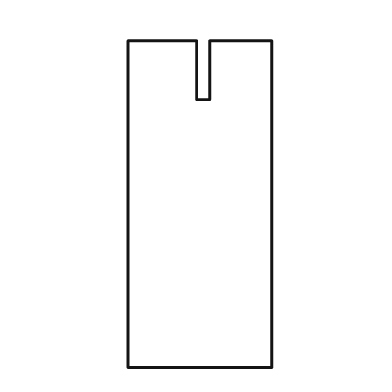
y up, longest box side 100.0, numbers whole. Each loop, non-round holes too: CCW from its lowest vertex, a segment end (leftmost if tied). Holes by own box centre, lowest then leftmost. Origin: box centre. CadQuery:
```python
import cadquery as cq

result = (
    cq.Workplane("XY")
    .moveTo(-22.0, -50.0)
    .lineTo(22.0, -50.0)
    .lineTo(22.0, 50.0)
    .lineTo(3.0, 50.0)
    .lineTo(3.0, 32.0)
    .lineTo(-1.0, 32.0)
    .lineTo(-1.0, 50.0)
    .lineTo(-22.0, 50.0)
    .close()
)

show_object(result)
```